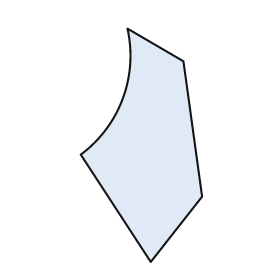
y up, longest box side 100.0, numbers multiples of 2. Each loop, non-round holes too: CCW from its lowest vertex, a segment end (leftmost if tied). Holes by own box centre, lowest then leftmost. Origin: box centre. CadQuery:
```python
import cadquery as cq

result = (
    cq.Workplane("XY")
    .moveTo(4.0, -50.0)
    .lineTo(26.0, -22.0)
    .lineTo(18.0, 36.0)
    .lineTo(-6.0, 50.0)
    .threePointArc((-8.0, 20.0), (-26.0, -4.0))
    .close()
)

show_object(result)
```